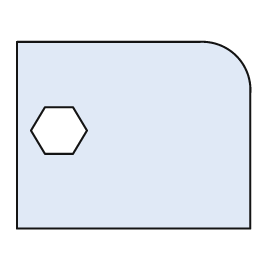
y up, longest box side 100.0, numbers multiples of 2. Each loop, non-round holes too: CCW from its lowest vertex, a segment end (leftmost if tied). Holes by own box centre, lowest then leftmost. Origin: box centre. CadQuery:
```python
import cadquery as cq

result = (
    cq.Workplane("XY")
    .moveTo(-50.0, -40.0)
    .lineTo(50.0, -40.0)
    .lineTo(50.0, 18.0)
    .threePointArc((44.0, 34.0), (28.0, 40.0))
    .lineTo(-50.0, 40.0)
    .close()
    .moveTo(-38.0, -8.0)
    .lineTo(-26.0, -8.0)
    .lineTo(-20.0, 2.0)
    .lineTo(-26.0, 12.0)
    .lineTo(-38.0, 12.0)
    .lineTo(-44.0, 2.0)
    .close()
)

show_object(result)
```